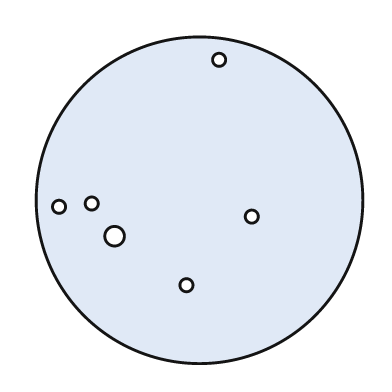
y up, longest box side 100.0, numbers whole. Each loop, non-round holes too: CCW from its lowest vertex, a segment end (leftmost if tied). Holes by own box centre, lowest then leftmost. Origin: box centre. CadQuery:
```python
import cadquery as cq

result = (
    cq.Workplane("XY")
    .moveTo(0.0, 0.0)
    .circle(50.0)
    .moveTo(-4.0, -26.0)
    .circle(2.0)
    .moveTo(-26.0, -11.0)
    .circle(3.0)
    .moveTo(16.0, -5.0)
    .circle(2.0)
    .moveTo(-43.0, -2.0)
    .circle(2.0)
    .moveTo(-33.0, -1.0)
    .circle(2.0)
    .moveTo(6.0, 43.0)
    .circle(2.0)
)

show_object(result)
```